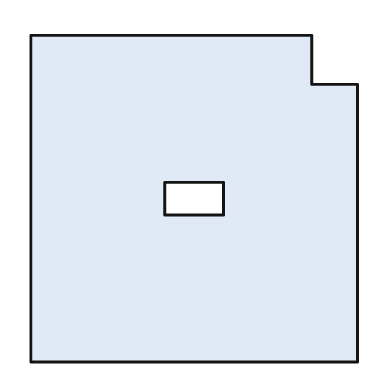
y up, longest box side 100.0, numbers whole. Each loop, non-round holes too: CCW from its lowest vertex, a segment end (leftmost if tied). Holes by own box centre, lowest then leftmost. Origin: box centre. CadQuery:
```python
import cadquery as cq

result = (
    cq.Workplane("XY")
    .moveTo(-50.0, -50.0)
    .lineTo(50.0, -50.0)
    .lineTo(50.0, 35.0)
    .lineTo(36.0, 35.0)
    .lineTo(36.0, 50.0)
    .lineTo(-50.0, 50.0)
    .close()
    .moveTo(-9.0, -5.0)
    .lineTo(9.0, -5.0)
    .lineTo(9.0, 5.0)
    .lineTo(-9.0, 5.0)
    .close()
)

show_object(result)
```